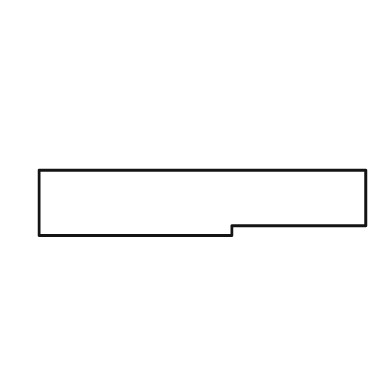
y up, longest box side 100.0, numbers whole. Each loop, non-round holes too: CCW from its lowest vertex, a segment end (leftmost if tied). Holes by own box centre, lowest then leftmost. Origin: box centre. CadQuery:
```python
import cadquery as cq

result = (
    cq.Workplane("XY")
    .moveTo(-50.0, -10.0)
    .lineTo(9.0, -10.0)
    .lineTo(9.0, -7.0)
    .lineTo(50.0, -7.0)
    .lineTo(50.0, 10.0)
    .lineTo(-50.0, 10.0)
    .close()
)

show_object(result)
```